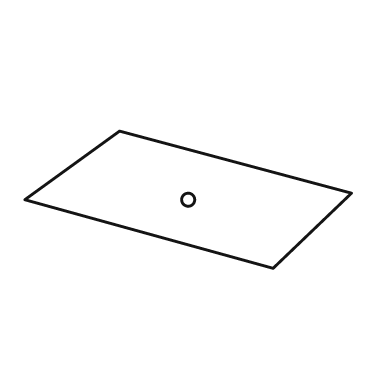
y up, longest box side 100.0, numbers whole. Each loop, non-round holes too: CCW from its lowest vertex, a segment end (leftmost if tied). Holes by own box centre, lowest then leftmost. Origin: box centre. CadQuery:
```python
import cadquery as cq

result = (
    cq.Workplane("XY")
    .moveTo(26.0, -21.0)
    .lineTo(50.0, 2.0)
    .lineTo(-21.0, 21.0)
    .lineTo(-50.0, 0.0)
    .close()
    .moveTo(0.0, 0.0)
    .circle(2.0)
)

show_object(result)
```